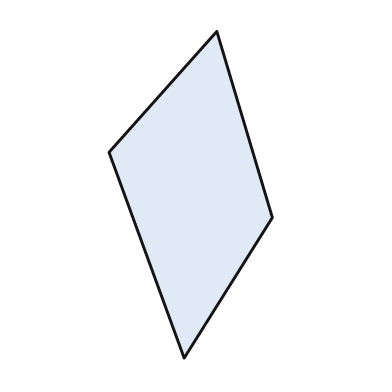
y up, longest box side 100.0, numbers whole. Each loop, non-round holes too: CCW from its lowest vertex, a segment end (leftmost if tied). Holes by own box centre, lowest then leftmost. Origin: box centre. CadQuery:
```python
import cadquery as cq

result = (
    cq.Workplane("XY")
    .moveTo(-2.0, -50.0)
    .lineTo(25.0, -7.0)
    .lineTo(8.0, 50.0)
    .lineTo(-25.0, 13.0)
    .close()
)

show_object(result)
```